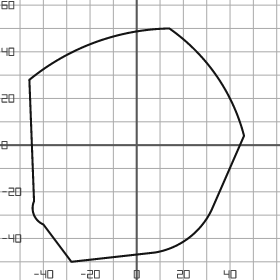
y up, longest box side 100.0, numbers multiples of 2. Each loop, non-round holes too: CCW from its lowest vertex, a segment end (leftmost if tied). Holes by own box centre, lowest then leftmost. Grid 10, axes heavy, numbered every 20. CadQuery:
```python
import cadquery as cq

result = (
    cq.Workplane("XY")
    .moveTo(-28.0, -50.0)
    .lineTo(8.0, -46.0)
    .threePointArc((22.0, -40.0), (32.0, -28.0))
    .lineTo(46.0, 4.0)
    .threePointArc((34.0, 30.0), (14.0, 50.0))
    .threePointArc((-18.0, 44.0), (-46.0, 28.0))
    .lineTo(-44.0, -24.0)
    .threePointArc((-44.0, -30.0), (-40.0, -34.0))
    .close()
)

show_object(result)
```